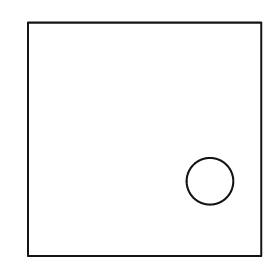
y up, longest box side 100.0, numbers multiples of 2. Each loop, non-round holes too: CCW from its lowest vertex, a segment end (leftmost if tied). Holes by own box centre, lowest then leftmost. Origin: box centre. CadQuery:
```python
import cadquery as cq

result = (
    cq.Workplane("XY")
    .moveTo(-50.0, -50.0)
    .lineTo(50.0, -50.0)
    .lineTo(50.0, 50.0)
    .lineTo(-50.0, 50.0)
    .close()
    .moveTo(28.0, -18.0)
    .circle(10.0)
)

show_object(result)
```